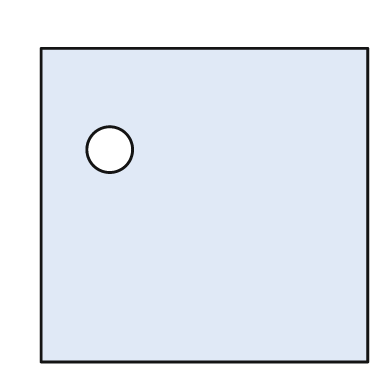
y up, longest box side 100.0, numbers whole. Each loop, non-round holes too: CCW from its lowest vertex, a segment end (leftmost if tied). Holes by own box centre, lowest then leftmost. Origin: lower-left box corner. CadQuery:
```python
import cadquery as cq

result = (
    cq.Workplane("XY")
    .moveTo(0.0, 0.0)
    .lineTo(100.0, 0.0)
    .lineTo(100.0, 96.0)
    .lineTo(0.0, 96.0)
    .close()
    .moveTo(21.0, 65.0)
    .circle(7.0)
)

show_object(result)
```